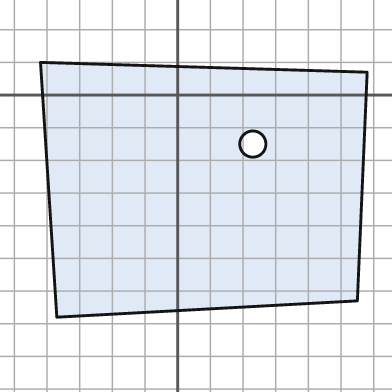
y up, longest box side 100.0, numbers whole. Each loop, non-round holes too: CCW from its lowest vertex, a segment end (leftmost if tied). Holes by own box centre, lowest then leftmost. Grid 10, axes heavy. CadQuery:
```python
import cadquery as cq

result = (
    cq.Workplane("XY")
    .moveTo(-37.0, -68.0)
    .lineTo(55.0, -63.0)
    .lineTo(58.0, 7.0)
    .lineTo(-42.0, 10.0)
    .close()
    .moveTo(23.0, -15.0)
    .circle(4.0)
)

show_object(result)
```